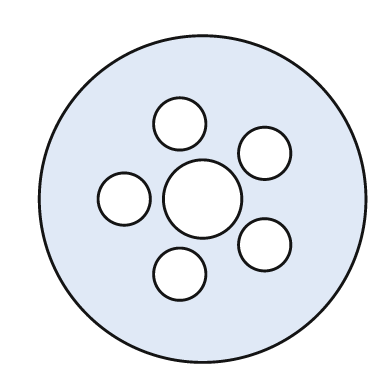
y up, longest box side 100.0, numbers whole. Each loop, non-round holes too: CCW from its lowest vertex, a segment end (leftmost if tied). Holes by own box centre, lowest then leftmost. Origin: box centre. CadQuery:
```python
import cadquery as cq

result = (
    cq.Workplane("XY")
    .moveTo(0.0, 0.0)
    .circle(50.0)
    .moveTo(-7.0, -23.0)
    .circle(8.0)
    .moveTo(19.0, -14.0)
    .circle(8.0)
    .moveTo(-24.0, 0.0)
    .circle(8.0)
    .moveTo(0.0, 0.0)
    .circle(12.0)
    .moveTo(19.0, 14.0)
    .circle(8.0)
    .moveTo(-7.0, 23.0)
    .circle(8.0)
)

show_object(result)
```